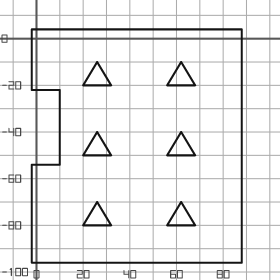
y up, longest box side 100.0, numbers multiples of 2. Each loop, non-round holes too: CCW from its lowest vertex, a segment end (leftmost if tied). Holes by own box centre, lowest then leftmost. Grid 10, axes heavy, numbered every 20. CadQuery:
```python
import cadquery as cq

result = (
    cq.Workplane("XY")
    .moveTo(-2.0, -96.0)
    .lineTo(88.0, -96.0)
    .lineTo(88.0, 4.0)
    .lineTo(-2.0, 4.0)
    .lineTo(-2.0, -22.0)
    .lineTo(10.0, -22.0)
    .lineTo(10.0, -54.0)
    .lineTo(-2.0, -54.0)
    .close()
    .moveTo(20.0, -80.0)
    .lineTo(32.0, -80.0)
    .lineTo(26.0, -70.0)
    .close()
    .moveTo(56.0, -80.0)
    .lineTo(68.0, -80.0)
    .lineTo(62.0, -70.0)
    .close()
    .moveTo(20.0, -50.0)
    .lineTo(32.0, -50.0)
    .lineTo(26.0, -40.0)
    .close()
    .moveTo(56.0, -50.0)
    .lineTo(68.0, -50.0)
    .lineTo(62.0, -40.0)
    .close()
    .moveTo(20.0, -20.0)
    .lineTo(32.0, -20.0)
    .lineTo(26.0, -10.0)
    .close()
    .moveTo(56.0, -20.0)
    .lineTo(68.0, -20.0)
    .lineTo(62.0, -10.0)
    .close()
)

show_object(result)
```